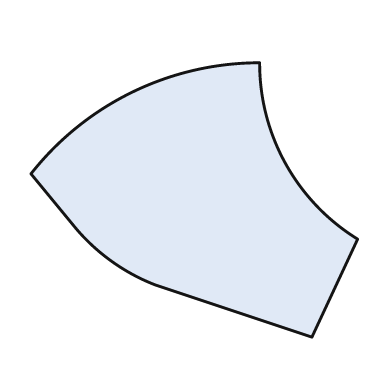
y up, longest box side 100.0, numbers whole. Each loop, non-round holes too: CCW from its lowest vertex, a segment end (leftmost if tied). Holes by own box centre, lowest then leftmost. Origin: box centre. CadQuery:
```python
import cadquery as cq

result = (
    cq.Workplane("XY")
    .moveTo(36.0, -42.0)
    .lineTo(50.0, -12.0)
    .threePointArc((28.0, 11.0), (20.0, 42.0))
    .threePointArc((-19.0, 33.0), (-50.0, 8.0))
    .lineTo(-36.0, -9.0)
    .threePointArc((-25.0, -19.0), (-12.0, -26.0))
    .close()
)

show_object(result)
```